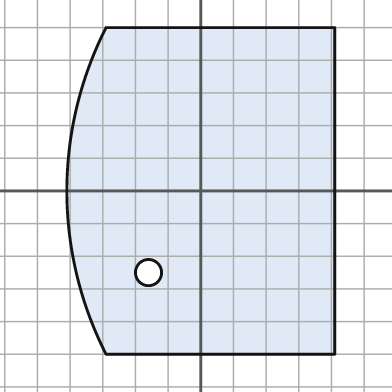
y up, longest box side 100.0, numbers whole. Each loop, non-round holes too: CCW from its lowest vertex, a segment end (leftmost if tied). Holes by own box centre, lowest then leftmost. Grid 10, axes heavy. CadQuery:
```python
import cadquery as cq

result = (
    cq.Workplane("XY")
    .moveTo(-29.0, -50.0)
    .lineTo(41.0, -50.0)
    .lineTo(41.0, 50.0)
    .lineTo(-29.0, 50.0)
    .threePointArc((-41.0, 0.0), (-29.0, -50.0))
    .close()
    .moveTo(-16.0, -25.0)
    .circle(4.0)
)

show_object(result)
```